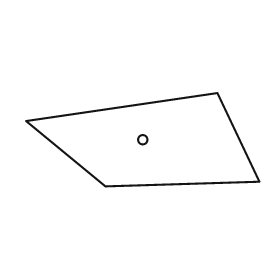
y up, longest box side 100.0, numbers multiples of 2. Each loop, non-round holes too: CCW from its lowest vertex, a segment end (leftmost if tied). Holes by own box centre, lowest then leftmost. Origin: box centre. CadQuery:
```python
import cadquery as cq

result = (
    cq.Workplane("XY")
    .moveTo(-16.0, -20.0)
    .lineTo(50.0, -18.0)
    .lineTo(32.0, 20.0)
    .lineTo(-50.0, 8.0)
    .close()
    .moveTo(0.0, 0.0)
    .circle(2.0)
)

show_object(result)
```